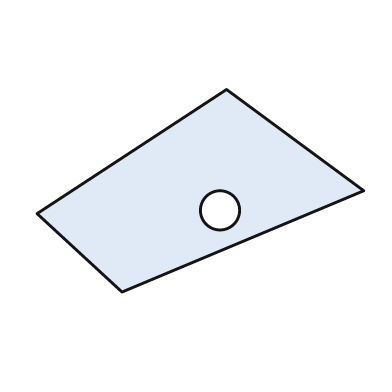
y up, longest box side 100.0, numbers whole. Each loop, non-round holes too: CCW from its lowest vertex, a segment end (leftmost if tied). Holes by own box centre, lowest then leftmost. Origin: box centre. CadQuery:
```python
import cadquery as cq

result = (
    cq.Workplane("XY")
    .moveTo(-24.0, -31.0)
    .lineTo(50.0, 0.0)
    .lineTo(8.0, 31.0)
    .lineTo(-50.0, -7.0)
    .close()
    .moveTo(6.0, -6.0)
    .circle(6.0)
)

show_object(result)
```